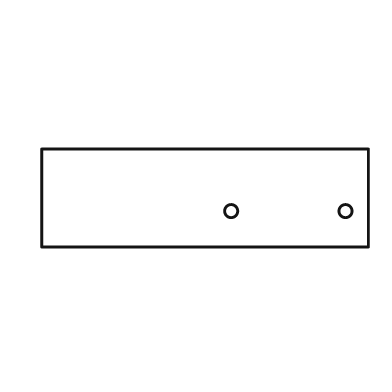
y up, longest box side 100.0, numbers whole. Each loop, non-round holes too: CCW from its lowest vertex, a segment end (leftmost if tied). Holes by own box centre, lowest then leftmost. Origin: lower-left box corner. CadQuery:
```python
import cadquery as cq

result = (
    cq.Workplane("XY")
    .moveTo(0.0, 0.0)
    .lineTo(100.0, 0.0)
    .lineTo(100.0, 30.0)
    .lineTo(0.0, 30.0)
    .close()
    .moveTo(58.0, 11.0)
    .circle(2.0)
    .moveTo(93.0, 11.0)
    .circle(2.0)
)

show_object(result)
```